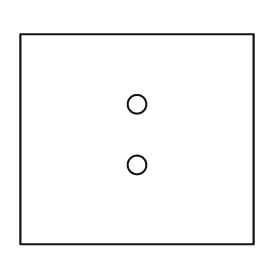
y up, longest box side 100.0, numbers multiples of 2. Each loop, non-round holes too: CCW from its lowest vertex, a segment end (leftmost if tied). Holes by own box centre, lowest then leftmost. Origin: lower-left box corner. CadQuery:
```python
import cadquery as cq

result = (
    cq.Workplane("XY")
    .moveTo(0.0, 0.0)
    .lineTo(100.0, 0.0)
    .lineTo(100.0, 90.0)
    .lineTo(0.0, 90.0)
    .close()
    .moveTo(50.0, 34.0)
    .circle(4.0)
    .moveTo(50.0, 60.0)
    .circle(4.0)
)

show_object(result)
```